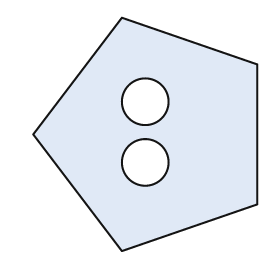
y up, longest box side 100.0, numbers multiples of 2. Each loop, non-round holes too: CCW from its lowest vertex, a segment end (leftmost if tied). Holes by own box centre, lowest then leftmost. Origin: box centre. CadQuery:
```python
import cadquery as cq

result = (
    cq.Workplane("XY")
    .moveTo(-10.0, -50.0)
    .lineTo(48.0, -30.0)
    .lineTo(48.0, 30.0)
    .lineTo(-10.0, 50.0)
    .lineTo(-48.0, 0.0)
    .close()
    .moveTo(0.0, -12.0)
    .circle(10.0)
    .moveTo(0.0, 14.0)
    .circle(10.0)
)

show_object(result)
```